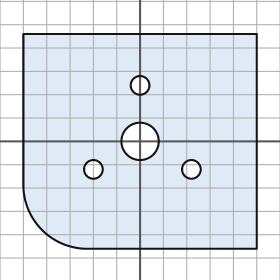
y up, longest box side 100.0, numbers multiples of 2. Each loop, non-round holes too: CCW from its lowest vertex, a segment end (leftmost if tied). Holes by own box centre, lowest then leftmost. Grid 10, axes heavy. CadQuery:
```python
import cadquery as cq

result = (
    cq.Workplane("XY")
    .moveTo(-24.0, -46.0)
    .lineTo(50.0, -46.0)
    .lineTo(50.0, 46.0)
    .lineTo(-50.0, 46.0)
    .lineTo(-50.0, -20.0)
    .threePointArc((-42.0, -38.0), (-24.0, -46.0))
    .close()
    .moveTo(-20.0, -12.0)
    .circle(4.0)
    .moveTo(22.0, -12.0)
    .circle(4.0)
    .moveTo(0.0, 0.0)
    .circle(8.0)
    .moveTo(0.0, 24.0)
    .circle(4.0)
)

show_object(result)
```